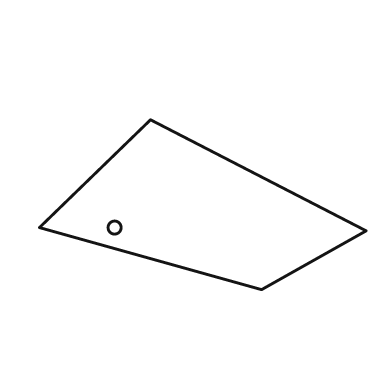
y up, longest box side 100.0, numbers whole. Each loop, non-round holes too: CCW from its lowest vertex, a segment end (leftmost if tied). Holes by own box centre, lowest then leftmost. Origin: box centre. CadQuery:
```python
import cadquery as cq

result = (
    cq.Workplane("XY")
    .moveTo(18.0, -26.0)
    .lineTo(50.0, -8.0)
    .lineTo(-16.0, 26.0)
    .lineTo(-50.0, -7.0)
    .close()
    .moveTo(-27.0, -7.0)
    .circle(2.0)
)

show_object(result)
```